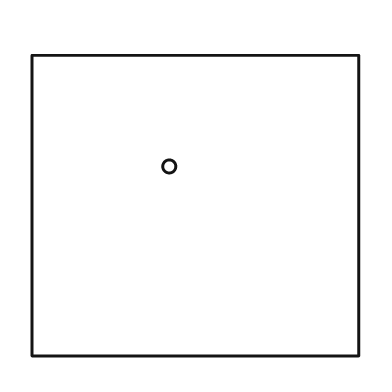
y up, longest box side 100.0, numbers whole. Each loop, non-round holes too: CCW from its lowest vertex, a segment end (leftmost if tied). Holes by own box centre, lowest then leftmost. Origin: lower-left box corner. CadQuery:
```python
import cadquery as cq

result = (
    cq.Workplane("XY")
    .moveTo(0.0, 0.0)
    .lineTo(100.0, 0.0)
    .lineTo(100.0, 92.0)
    .lineTo(0.0, 92.0)
    .close()
    .moveTo(42.0, 58.0)
    .circle(2.0)
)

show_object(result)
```